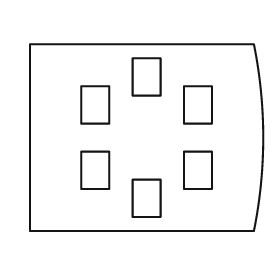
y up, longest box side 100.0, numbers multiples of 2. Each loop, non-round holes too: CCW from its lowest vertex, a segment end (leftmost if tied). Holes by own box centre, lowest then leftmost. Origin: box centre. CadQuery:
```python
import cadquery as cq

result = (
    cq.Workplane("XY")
    .moveTo(-50.0, -40.0)
    .lineTo(46.0, -40.0)
    .threePointArc((50.0, 0.0), (46.0, 40.0))
    .lineTo(-50.0, 40.0)
    .close()
    .moveTo(-6.0, -34.0)
    .lineTo(6.0, -34.0)
    .lineTo(6.0, -18.0)
    .lineTo(-6.0, -18.0)
    .close()
    .moveTo(-28.0, -22.0)
    .lineTo(-16.0, -22.0)
    .lineTo(-16.0, -6.0)
    .lineTo(-28.0, -6.0)
    .close()
    .moveTo(16.0, -22.0)
    .lineTo(28.0, -22.0)
    .lineTo(28.0, -6.0)
    .lineTo(16.0, -6.0)
    .close()
    .moveTo(-28.0, 6.0)
    .lineTo(-16.0, 6.0)
    .lineTo(-16.0, 22.0)
    .lineTo(-28.0, 22.0)
    .close()
    .moveTo(16.0, 6.0)
    .lineTo(28.0, 6.0)
    .lineTo(28.0, 22.0)
    .lineTo(16.0, 22.0)
    .close()
    .moveTo(-6.0, 18.0)
    .lineTo(6.0, 18.0)
    .lineTo(6.0, 34.0)
    .lineTo(-6.0, 34.0)
    .close()
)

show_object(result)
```